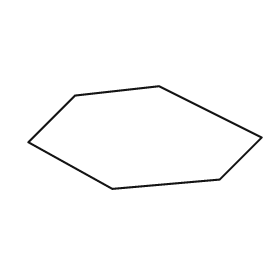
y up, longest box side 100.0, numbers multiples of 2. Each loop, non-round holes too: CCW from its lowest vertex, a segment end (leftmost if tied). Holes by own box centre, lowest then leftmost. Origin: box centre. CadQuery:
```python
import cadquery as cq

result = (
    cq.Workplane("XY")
    .moveTo(-14.0, -22.0)
    .lineTo(32.0, -18.0)
    .lineTo(50.0, 0.0)
    .lineTo(6.0, 22.0)
    .lineTo(-30.0, 18.0)
    .lineTo(-50.0, -2.0)
    .close()
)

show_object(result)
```